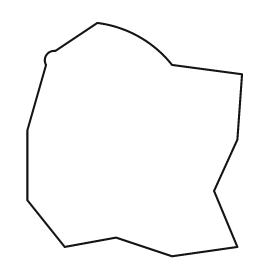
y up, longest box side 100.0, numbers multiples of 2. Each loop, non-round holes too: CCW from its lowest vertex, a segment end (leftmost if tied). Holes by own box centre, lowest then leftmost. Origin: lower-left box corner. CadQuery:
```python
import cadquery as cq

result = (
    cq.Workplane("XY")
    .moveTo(62.0, 0.0)
    .lineTo(90.0, 4.0)
    .lineTo(80.0, 28.0)
    .lineTo(90.0, 50.0)
    .lineTo(92.0, 78.0)
    .lineTo(62.0, 82.0)
    .threePointArc((48.0, 94.0), (30.0, 100.0))
    .lineTo(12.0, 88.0)
    .threePointArc((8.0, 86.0), (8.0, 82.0))
    .lineTo(0.0, 54.0)
    .lineTo(0.0, 24.0)
    .lineTo(16.0, 4.0)
    .lineTo(38.0, 8.0)
    .close()
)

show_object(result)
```